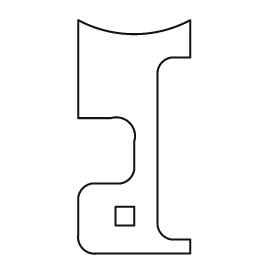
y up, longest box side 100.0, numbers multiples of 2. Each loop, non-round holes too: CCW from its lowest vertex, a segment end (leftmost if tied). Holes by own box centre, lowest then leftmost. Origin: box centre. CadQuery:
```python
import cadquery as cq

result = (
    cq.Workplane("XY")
    .moveTo(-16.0, -50.0)
    .lineTo(24.0, -50.0)
    .lineTo(24.0, -44.0)
    .lineTo(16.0, -44.0)
    .threePointArc((12.0, -42.0), (10.0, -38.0))
    .lineTo(10.0, 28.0)
    .threePointArc((12.0, 32.0), (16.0, 34.0))
    .lineTo(24.0, 34.0)
    .lineTo(24.0, 50.0)
    .threePointArc((0.0, 44.0), (-24.0, 50.0))
    .lineTo(-24.0, 8.0)
    .lineTo(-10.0, 8.0)
    .threePointArc((-2.0, 6.0), (0.0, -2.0))
    .lineTo(0.0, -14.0)
    .threePointArc((-2.0, -18.0), (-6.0, -20.0))
    .lineTo(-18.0, -20.0)
    .threePointArc((-22.0, -22.0), (-24.0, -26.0))
    .lineTo(-24.0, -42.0)
    .threePointArc((-22.0, -48.0), (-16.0, -50.0))
    .close()
    .moveTo(-8.0, -38.0)
    .lineTo(0.0, -38.0)
    .lineTo(0.0, -30.0)
    .lineTo(-8.0, -30.0)
    .close()
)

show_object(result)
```